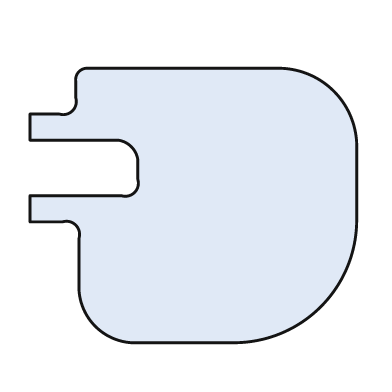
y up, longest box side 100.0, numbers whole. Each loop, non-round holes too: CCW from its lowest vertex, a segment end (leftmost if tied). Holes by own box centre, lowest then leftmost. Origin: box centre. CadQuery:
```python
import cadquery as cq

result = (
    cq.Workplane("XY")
    .moveTo(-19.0, -42.0)
    .lineTo(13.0, -42.0)
    .threePointArc((39.0, -31.0), (50.0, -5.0))
    .lineTo(50.0, 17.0)
    .threePointArc((43.0, 35.0), (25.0, 42.0))
    .lineTo(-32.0, 42.0)
    .threePointArc((-35.0, 41.0), (-36.0, 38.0))
    .lineTo(-36.0, 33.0)
    .threePointArc((-37.0, 29.0), (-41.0, 28.0))
    .lineTo(-50.0, 28.0)
    .lineTo(-50.0, 20.0)
    .lineTo(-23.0, 20.0)
    .threePointArc((-19.0, 18.0), (-17.0, 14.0))
    .lineTo(-17.0, 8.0)
    .threePointArc((-18.0, 4.0), (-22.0, 3.0))
    .lineTo(-50.0, 3.0)
    .lineTo(-50.0, -5.0)
    .lineTo(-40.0, -5.0)
    .threePointArc((-36.0, -6.0), (-35.0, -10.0))
    .lineTo(-35.0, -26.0)
    .threePointArc((-30.0, -37.0), (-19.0, -42.0))
    .close()
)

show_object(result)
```